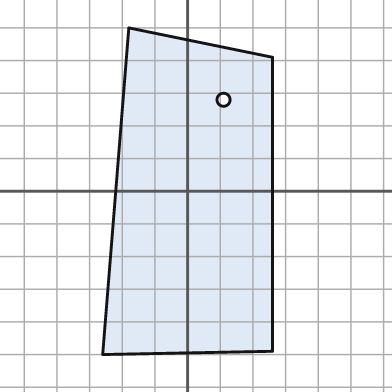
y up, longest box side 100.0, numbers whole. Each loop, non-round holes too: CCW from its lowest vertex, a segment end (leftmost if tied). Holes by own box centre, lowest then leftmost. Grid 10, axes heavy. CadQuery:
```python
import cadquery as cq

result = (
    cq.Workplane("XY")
    .moveTo(-26.0, -50.0)
    .lineTo(26.0, -49.0)
    .lineTo(26.0, 41.0)
    .lineTo(-18.0, 50.0)
    .close()
    .moveTo(11.0, 28.0)
    .circle(2.0)
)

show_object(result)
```